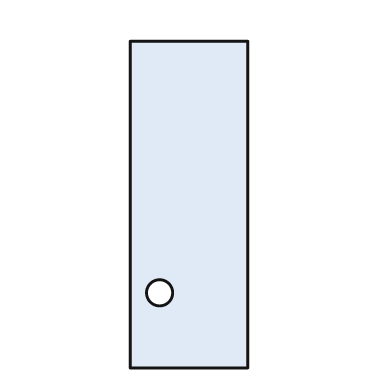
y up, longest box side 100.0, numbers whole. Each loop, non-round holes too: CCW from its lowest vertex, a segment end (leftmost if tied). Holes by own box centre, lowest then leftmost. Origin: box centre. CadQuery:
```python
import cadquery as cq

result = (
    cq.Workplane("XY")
    .moveTo(-18.0, -50.0)
    .lineTo(18.0, -50.0)
    .lineTo(18.0, 50.0)
    .lineTo(-18.0, 50.0)
    .close()
    .moveTo(-9.0, -27.0)
    .circle(4.0)
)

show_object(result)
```